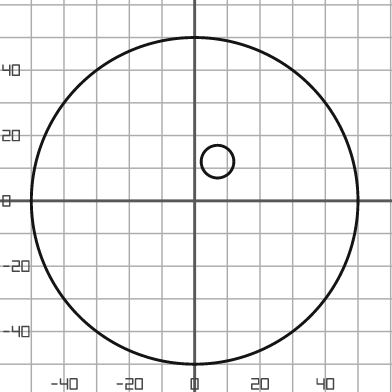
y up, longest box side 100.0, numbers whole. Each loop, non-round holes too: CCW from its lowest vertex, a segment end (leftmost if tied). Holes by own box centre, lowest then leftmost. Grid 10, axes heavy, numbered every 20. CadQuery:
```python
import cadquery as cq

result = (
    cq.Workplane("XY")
    .moveTo(0.0, 0.0)
    .circle(50.0)
    .moveTo(7.0, 12.0)
    .circle(5.0)
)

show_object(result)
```